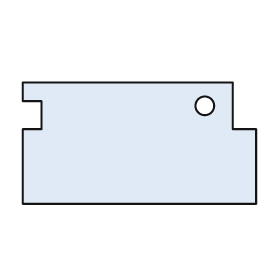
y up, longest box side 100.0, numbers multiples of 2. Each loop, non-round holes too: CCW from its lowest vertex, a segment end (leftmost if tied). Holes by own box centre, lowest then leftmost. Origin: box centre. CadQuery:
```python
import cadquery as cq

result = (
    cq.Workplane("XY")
    .moveTo(-50.0, -26.0)
    .lineTo(50.0, -26.0)
    .lineTo(50.0, 6.0)
    .lineTo(40.0, 6.0)
    .lineTo(40.0, 26.0)
    .lineTo(-50.0, 26.0)
    .lineTo(-50.0, 18.0)
    .lineTo(-42.0, 18.0)
    .lineTo(-42.0, 6.0)
    .lineTo(-50.0, 6.0)
    .close()
    .moveTo(28.0, 16.0)
    .circle(4.0)
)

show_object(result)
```